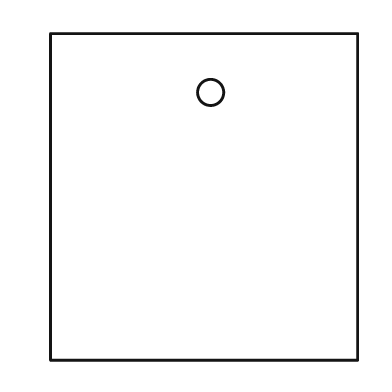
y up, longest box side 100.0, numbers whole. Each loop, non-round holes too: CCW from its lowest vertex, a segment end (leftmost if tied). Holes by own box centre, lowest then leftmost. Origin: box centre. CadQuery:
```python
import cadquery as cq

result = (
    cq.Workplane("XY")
    .moveTo(-47.0, -50.0)
    .lineTo(47.0, -50.0)
    .lineTo(47.0, 50.0)
    .lineTo(-47.0, 50.0)
    .close()
    .moveTo(2.0, 32.0)
    .circle(4.0)
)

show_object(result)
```